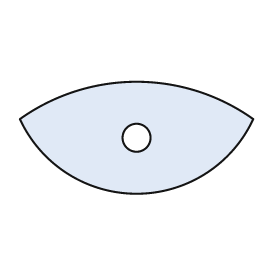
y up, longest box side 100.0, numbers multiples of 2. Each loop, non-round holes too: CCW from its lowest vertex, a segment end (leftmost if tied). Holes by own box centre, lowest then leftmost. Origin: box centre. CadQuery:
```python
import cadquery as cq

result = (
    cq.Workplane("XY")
    .moveTo(-50.0, 8.0)
    .threePointArc((0.0, -24.0), (50.0, 8.0))
    .threePointArc((0.0, 24.0), (-50.0, 8.0))
    .close()
    .moveTo(0.0, 0.0)
    .circle(6.0)
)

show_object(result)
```